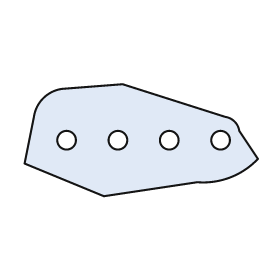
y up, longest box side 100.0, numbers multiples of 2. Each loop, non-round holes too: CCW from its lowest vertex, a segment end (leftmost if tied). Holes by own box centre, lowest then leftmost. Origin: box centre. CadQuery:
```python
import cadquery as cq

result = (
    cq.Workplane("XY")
    .moveTo(-16.0, -24.0)
    .lineTo(24.0, -18.0)
    .threePointArc((38.0, -16.0), (50.0, -8.0))
    .lineTo(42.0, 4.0)
    .threePointArc((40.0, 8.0), (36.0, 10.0))
    .lineTo(-8.0, 24.0)
    .lineTo(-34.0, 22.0)
    .threePointArc((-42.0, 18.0), (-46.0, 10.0))
    .lineTo(-50.0, -10.0)
    .close()
    .moveTo(-32.0, 0.0)
    .circle(4.0)
    .moveTo(-10.0, 0.0)
    .circle(4.0)
    .moveTo(12.0, 0.0)
    .circle(4.0)
    .moveTo(34.0, 0.0)
    .circle(4.0)
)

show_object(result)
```